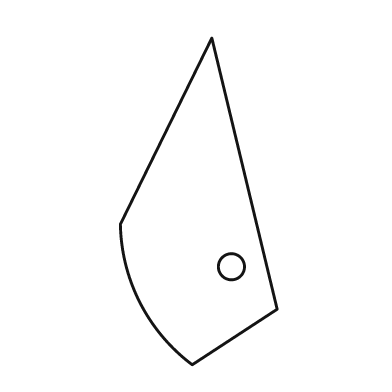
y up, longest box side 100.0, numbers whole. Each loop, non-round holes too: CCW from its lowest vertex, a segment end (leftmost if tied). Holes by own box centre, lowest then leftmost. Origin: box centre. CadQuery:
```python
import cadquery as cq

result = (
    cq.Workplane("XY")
    .moveTo(-2.0, -50.0)
    .lineTo(24.0, -33.0)
    .lineTo(4.0, 50.0)
    .lineTo(-24.0, -7.0)
    .threePointArc((-18.0, -31.0), (-2.0, -50.0))
    .close()
    .moveTo(10.0, -20.0)
    .circle(4.0)
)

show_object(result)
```